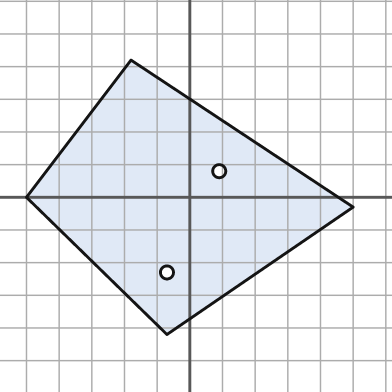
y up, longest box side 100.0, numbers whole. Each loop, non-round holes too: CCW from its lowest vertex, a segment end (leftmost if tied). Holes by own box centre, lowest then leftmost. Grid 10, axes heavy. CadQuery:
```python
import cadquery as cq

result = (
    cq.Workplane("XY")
    .moveTo(-7.0, -42.0)
    .lineTo(50.0, -3.0)
    .lineTo(-18.0, 42.0)
    .lineTo(-50.0, 0.0)
    .close()
    .moveTo(-7.0, -23.0)
    .circle(2.0)
    .moveTo(9.0, 8.0)
    .circle(2.0)
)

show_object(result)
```